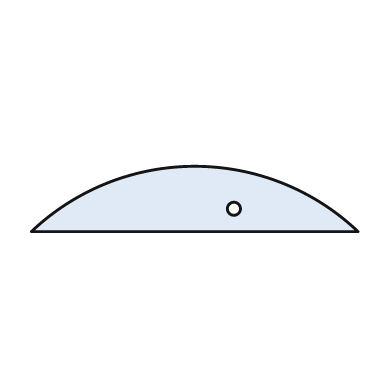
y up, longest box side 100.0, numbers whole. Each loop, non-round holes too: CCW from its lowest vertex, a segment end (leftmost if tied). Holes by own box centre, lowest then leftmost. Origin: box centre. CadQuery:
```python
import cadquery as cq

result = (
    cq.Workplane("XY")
    .moveTo(-50.0, -10.0)
    .lineTo(50.0, -10.0)
    .threePointArc((0.0, 10.0), (-50.0, -10.0))
    .close()
    .moveTo(12.0, -3.0)
    .circle(2.0)
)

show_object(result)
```